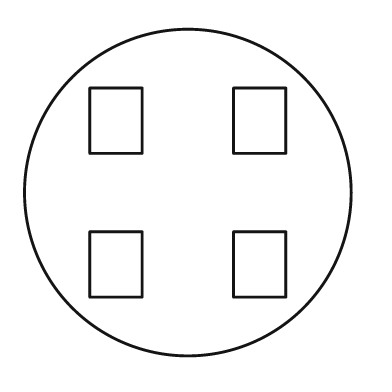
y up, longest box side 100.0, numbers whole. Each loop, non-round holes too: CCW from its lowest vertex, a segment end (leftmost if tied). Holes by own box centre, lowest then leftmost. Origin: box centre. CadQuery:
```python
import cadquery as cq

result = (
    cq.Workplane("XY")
    .moveTo(0.0, 0.0)
    .circle(50.0)
    .moveTo(-30.0, -32.0)
    .lineTo(-14.0, -32.0)
    .lineTo(-14.0, -12.0)
    .lineTo(-30.0, -12.0)
    .close()
    .moveTo(14.0, -32.0)
    .lineTo(30.0, -32.0)
    .lineTo(30.0, -12.0)
    .lineTo(14.0, -12.0)
    .close()
    .moveTo(-30.0, 12.0)
    .lineTo(-14.0, 12.0)
    .lineTo(-14.0, 32.0)
    .lineTo(-30.0, 32.0)
    .close()
    .moveTo(14.0, 12.0)
    .lineTo(30.0, 12.0)
    .lineTo(30.0, 32.0)
    .lineTo(14.0, 32.0)
    .close()
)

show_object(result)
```